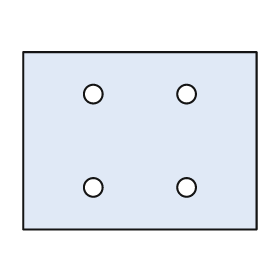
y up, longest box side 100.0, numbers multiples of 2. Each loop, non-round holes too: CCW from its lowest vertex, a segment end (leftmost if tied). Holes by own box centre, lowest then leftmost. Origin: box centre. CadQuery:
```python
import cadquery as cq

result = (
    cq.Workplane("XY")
    .moveTo(-50.0, -38.0)
    .lineTo(50.0, -38.0)
    .lineTo(50.0, 38.0)
    .lineTo(-50.0, 38.0)
    .close()
    .moveTo(-20.0, -20.0)
    .circle(4.0)
    .moveTo(20.0, -20.0)
    .circle(4.0)
    .moveTo(-20.0, 20.0)
    .circle(4.0)
    .moveTo(20.0, 20.0)
    .circle(4.0)
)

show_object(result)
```